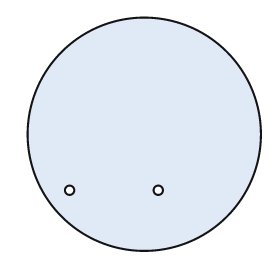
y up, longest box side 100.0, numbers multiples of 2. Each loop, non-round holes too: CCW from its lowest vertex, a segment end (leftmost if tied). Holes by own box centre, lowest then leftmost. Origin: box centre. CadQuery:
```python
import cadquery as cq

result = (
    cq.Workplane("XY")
    .moveTo(0.0, 0.0)
    .circle(50.0)
    .moveTo(-32.0, -24.0)
    .circle(2.0)
    .moveTo(6.0, -24.0)
    .circle(2.0)
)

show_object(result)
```